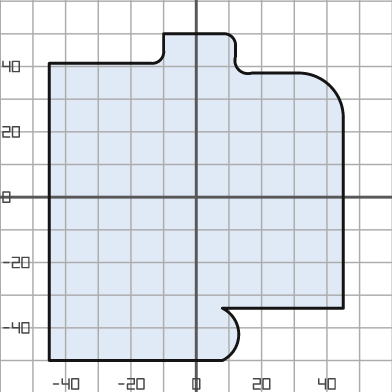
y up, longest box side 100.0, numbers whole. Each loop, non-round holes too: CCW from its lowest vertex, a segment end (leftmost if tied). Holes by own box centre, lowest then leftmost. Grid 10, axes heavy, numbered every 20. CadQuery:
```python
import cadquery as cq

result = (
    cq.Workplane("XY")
    .moveTo(-45.0, -50.0)
    .lineTo(8.0, -50.0)
    .threePointArc((13.0, -42.0), (8.0, -34.0))
    .lineTo(45.0, -34.0)
    .lineTo(45.0, 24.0)
    .threePointArc((41.0, 34.0), (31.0, 38.0))
    .lineTo(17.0, 38.0)
    .threePointArc((13.0, 39.0), (12.0, 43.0))
    .lineTo(12.0, 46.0)
    .threePointArc((11.0, 49.0), (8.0, 50.0))
    .lineTo(-10.0, 50.0)
    .lineTo(-10.0, 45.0)
    .threePointArc((-11.0, 42.0), (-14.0, 41.0))
    .lineTo(-45.0, 41.0)
    .close()
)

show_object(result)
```